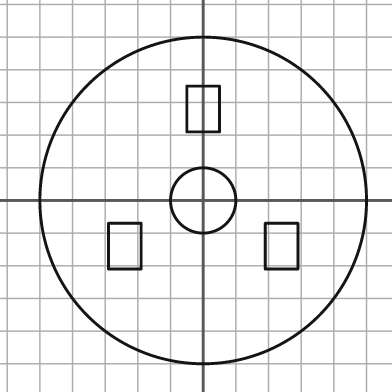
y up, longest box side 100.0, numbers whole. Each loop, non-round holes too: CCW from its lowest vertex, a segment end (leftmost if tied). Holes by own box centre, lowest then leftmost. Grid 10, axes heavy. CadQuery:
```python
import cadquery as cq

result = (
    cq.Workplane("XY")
    .moveTo(0.0, 0.0)
    .circle(50.0)
    .moveTo(-29.0, -21.0)
    .lineTo(-19.0, -21.0)
    .lineTo(-19.0, -7.0)
    .lineTo(-29.0, -7.0)
    .close()
    .moveTo(19.0, -21.0)
    .lineTo(29.0, -21.0)
    .lineTo(29.0, -7.0)
    .lineTo(19.0, -7.0)
    .close()
    .moveTo(0.0, 0.0)
    .circle(10.0)
    .moveTo(-5.0, 21.0)
    .lineTo(5.0, 21.0)
    .lineTo(5.0, 35.0)
    .lineTo(-5.0, 35.0)
    .close()
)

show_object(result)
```